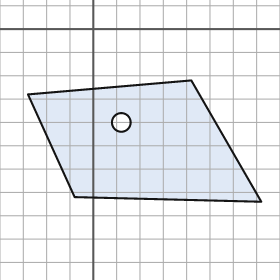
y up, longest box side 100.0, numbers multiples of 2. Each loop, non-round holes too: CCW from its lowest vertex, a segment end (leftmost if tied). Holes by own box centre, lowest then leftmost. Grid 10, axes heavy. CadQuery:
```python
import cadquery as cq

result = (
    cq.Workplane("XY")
    .moveTo(72.0, -74.0)
    .lineTo(42.0, -22.0)
    .lineTo(-28.0, -28.0)
    .lineTo(-8.0, -72.0)
    .close()
    .moveTo(12.0, -40.0)
    .circle(4.0)
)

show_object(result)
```